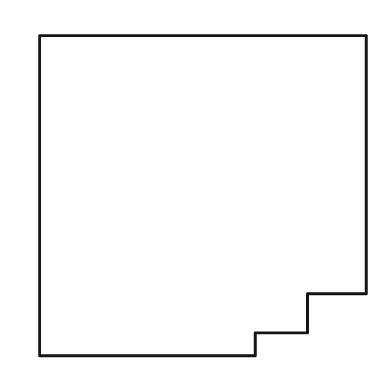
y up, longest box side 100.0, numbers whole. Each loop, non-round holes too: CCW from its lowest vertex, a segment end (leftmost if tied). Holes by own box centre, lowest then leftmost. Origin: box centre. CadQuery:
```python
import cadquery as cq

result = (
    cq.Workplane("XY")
    .moveTo(-50.0, -49.0)
    .lineTo(16.0, -49.0)
    .lineTo(16.0, -42.0)
    .lineTo(32.0, -42.0)
    .lineTo(32.0, -30.0)
    .lineTo(50.0, -30.0)
    .lineTo(50.0, 49.0)
    .lineTo(-50.0, 49.0)
    .close()
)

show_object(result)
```